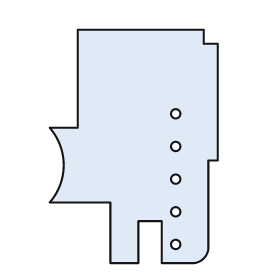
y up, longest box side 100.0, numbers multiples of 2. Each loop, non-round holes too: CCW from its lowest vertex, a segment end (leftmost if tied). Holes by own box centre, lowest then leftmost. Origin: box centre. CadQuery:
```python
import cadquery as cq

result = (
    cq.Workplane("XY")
    .moveTo(-10.0, -50.0)
    .lineTo(2.0, -50.0)
    .lineTo(2.0, -32.0)
    .lineTo(12.0, -32.0)
    .lineTo(12.0, -50.0)
    .lineTo(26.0, -50.0)
    .threePointArc((30.0, -48.0), (32.0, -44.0))
    .lineTo(32.0, -6.0)
    .lineTo(36.0, -6.0)
    .lineTo(36.0, 44.0)
    .lineTo(30.0, 44.0)
    .lineTo(30.0, 50.0)
    .lineTo(-24.0, 50.0)
    .lineTo(-24.0, 8.0)
    .lineTo(-36.0, 8.0)
    .threePointArc((-30.0, -8.0), (-36.0, -24.0))
    .lineTo(-10.0, -24.0)
    .close()
    .moveTo(18.0, -42.0)
    .circle(2.0)
    .moveTo(18.0, -28.0)
    .circle(2.0)
    .moveTo(18.0, -14.0)
    .circle(2.0)
    .moveTo(18.0, 0.0)
    .circle(2.0)
    .moveTo(18.0, 14.0)
    .circle(2.0)
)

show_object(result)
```